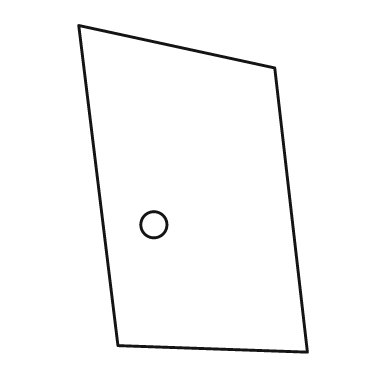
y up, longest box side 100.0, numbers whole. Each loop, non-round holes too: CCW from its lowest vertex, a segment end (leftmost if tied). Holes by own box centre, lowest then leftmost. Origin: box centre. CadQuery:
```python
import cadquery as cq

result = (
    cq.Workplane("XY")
    .moveTo(35.0, -50.0)
    .lineTo(25.0, 37.0)
    .lineTo(-35.0, 50.0)
    .lineTo(-23.0, -48.0)
    .close()
    .moveTo(-12.0, -11.0)
    .circle(4.0)
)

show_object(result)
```